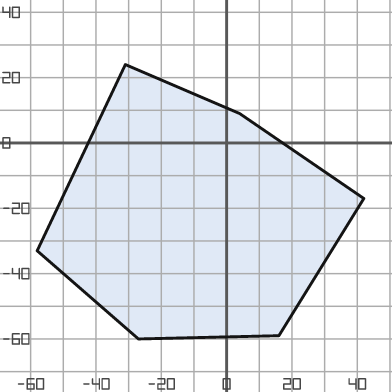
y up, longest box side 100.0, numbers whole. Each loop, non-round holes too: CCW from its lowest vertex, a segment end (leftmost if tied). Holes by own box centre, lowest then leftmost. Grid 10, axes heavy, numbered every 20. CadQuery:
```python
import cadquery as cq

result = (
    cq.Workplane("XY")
    .moveTo(-27.0, -60.0)
    .lineTo(16.0, -59.0)
    .lineTo(42.0, -17.0)
    .lineTo(4.0, 9.0)
    .lineTo(-31.0, 24.0)
    .lineTo(-58.0, -33.0)
    .close()
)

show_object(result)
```